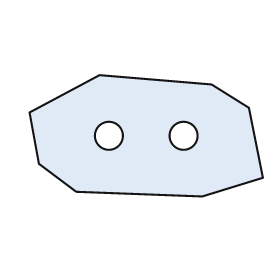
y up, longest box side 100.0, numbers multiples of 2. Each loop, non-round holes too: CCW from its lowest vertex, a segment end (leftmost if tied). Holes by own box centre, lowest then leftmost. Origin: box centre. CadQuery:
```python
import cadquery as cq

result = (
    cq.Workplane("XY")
    .moveTo(24.0, -26.0)
    .lineTo(50.0, -18.0)
    .lineTo(44.0, 12.0)
    .lineTo(28.0, 22.0)
    .lineTo(-20.0, 26.0)
    .lineTo(-50.0, 10.0)
    .lineTo(-46.0, -12.0)
    .lineTo(-30.0, -24.0)
    .close()
    .moveTo(-16.0, 0.0)
    .circle(6.0)
    .moveTo(16.0, 0.0)
    .circle(6.0)
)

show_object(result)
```